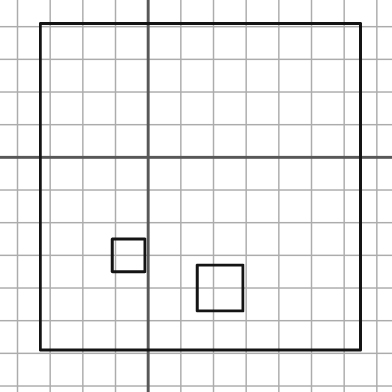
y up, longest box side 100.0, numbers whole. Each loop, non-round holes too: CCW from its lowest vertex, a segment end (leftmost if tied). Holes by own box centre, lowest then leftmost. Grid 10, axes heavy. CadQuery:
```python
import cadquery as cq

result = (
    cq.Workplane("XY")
    .moveTo(-33.0, -59.0)
    .lineTo(65.0, -59.0)
    .lineTo(65.0, 41.0)
    .lineTo(-33.0, 41.0)
    .close()
    .moveTo(15.0, -47.0)
    .lineTo(29.0, -47.0)
    .lineTo(29.0, -33.0)
    .lineTo(15.0, -33.0)
    .close()
    .moveTo(-11.0, -35.0)
    .lineTo(-1.0, -35.0)
    .lineTo(-1.0, -25.0)
    .lineTo(-11.0, -25.0)
    .close()
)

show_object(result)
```